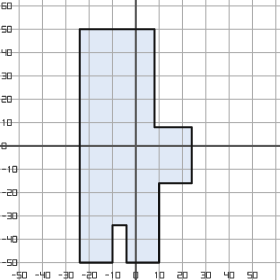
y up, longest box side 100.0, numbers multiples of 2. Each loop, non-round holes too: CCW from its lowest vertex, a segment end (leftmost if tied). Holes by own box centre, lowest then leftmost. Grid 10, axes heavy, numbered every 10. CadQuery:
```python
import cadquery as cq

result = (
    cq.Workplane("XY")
    .moveTo(-24.0, -50.0)
    .lineTo(-10.0, -50.0)
    .lineTo(-10.0, -34.0)
    .lineTo(-4.0, -34.0)
    .lineTo(-4.0, -50.0)
    .lineTo(10.0, -50.0)
    .lineTo(10.0, -16.0)
    .lineTo(24.0, -16.0)
    .lineTo(24.0, 8.0)
    .lineTo(8.0, 8.0)
    .lineTo(8.0, 50.0)
    .lineTo(-24.0, 50.0)
    .close()
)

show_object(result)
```